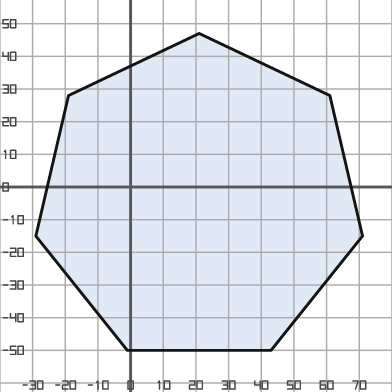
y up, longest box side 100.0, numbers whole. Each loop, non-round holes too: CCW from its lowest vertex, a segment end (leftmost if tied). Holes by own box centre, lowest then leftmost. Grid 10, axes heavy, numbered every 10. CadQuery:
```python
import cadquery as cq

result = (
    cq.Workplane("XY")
    .moveTo(-1.0, -50.0)
    .lineTo(43.0, -50.0)
    .lineTo(71.0, -15.0)
    .lineTo(61.0, 28.0)
    .lineTo(21.0, 47.0)
    .lineTo(-19.0, 28.0)
    .lineTo(-29.0, -15.0)
    .close()
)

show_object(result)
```